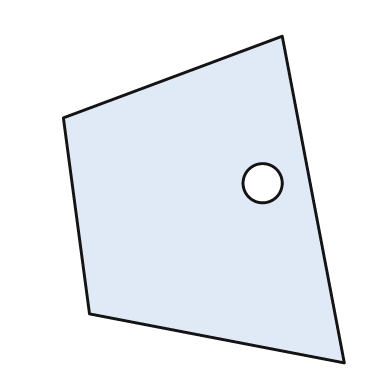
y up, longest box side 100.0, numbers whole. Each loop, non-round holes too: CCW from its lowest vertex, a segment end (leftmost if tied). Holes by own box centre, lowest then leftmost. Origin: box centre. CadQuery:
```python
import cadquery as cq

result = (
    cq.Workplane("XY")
    .moveTo(43.0, -50.0)
    .lineTo(24.0, 50.0)
    .lineTo(-43.0, 25.0)
    .lineTo(-35.0, -35.0)
    .close()
    .moveTo(18.0, 5.0)
    .circle(6.0)
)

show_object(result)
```